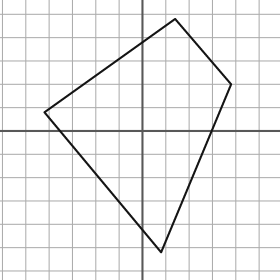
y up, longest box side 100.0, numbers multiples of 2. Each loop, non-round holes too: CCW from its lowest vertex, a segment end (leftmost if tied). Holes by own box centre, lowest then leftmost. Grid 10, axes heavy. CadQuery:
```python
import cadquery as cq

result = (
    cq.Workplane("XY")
    .moveTo(8.0, -52.0)
    .lineTo(38.0, 20.0)
    .lineTo(14.0, 48.0)
    .lineTo(-42.0, 8.0)
    .close()
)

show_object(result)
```